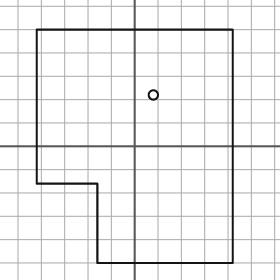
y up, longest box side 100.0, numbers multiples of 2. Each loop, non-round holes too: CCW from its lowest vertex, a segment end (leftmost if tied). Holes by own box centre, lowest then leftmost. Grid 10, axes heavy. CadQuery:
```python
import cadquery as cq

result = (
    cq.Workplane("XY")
    .moveTo(-16.0, -50.0)
    .lineTo(42.0, -50.0)
    .lineTo(42.0, 50.0)
    .lineTo(-42.0, 50.0)
    .lineTo(-42.0, -16.0)
    .lineTo(-16.0, -16.0)
    .close()
    .moveTo(8.0, 22.0)
    .circle(2.0)
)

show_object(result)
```